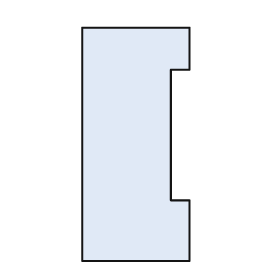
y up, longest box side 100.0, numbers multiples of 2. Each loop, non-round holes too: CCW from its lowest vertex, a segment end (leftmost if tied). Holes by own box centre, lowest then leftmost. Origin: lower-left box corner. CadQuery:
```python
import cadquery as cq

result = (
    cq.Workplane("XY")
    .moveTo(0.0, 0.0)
    .lineTo(46.0, 0.0)
    .lineTo(46.0, 26.0)
    .lineTo(38.0, 26.0)
    .lineTo(38.0, 82.0)
    .lineTo(46.0, 82.0)
    .lineTo(46.0, 100.0)
    .lineTo(0.0, 100.0)
    .close()
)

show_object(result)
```